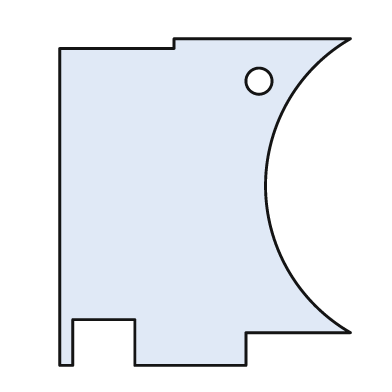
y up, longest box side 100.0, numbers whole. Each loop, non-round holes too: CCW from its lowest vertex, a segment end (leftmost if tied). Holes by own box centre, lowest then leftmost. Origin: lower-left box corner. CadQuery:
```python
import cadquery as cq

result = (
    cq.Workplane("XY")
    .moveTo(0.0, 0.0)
    .lineTo(4.0, 0.0)
    .lineTo(4.0, 14.0)
    .lineTo(23.0, 14.0)
    .lineTo(23.0, 0.0)
    .lineTo(57.0, 0.0)
    .lineTo(57.0, 10.0)
    .lineTo(89.0, 10.0)
    .threePointArc((63.0, 55.0), (89.0, 100.0))
    .lineTo(35.0, 100.0)
    .lineTo(35.0, 97.0)
    .lineTo(0.0, 97.0)
    .close()
    .moveTo(61.0, 87.0)
    .circle(4.0)
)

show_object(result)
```